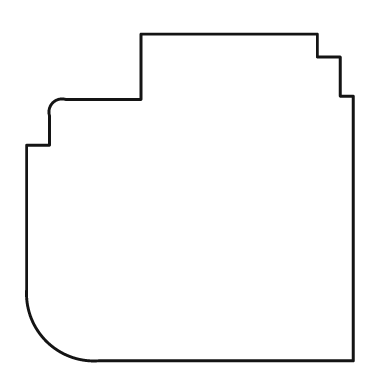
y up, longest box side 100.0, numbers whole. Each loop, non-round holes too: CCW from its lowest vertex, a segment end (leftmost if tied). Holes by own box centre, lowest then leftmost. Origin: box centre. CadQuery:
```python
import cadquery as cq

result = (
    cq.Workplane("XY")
    .moveTo(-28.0, -50.0)
    .lineTo(50.0, -50.0)
    .lineTo(50.0, 31.0)
    .lineTo(46.0, 31.0)
    .lineTo(46.0, 43.0)
    .lineTo(39.0, 43.0)
    .lineTo(39.0, 50.0)
    .lineTo(-15.0, 50.0)
    .lineTo(-15.0, 30.0)
    .lineTo(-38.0, 30.0)
    .threePointArc((-42.0, 29.0), (-43.0, 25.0))
    .lineTo(-43.0, 16.0)
    .lineTo(-50.0, 16.0)
    .lineTo(-50.0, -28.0)
    .threePointArc((-44.0, -44.0), (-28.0, -50.0))
    .close()
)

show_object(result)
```